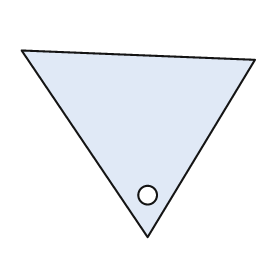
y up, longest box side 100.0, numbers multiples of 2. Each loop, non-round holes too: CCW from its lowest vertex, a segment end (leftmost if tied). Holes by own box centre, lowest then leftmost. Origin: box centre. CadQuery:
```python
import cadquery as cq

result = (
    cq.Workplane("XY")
    .moveTo(4.0, -40.0)
    .lineTo(50.0, 36.0)
    .lineTo(-50.0, 40.0)
    .close()
    .moveTo(4.0, -22.0)
    .circle(4.0)
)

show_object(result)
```